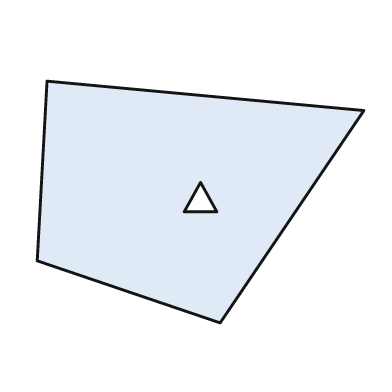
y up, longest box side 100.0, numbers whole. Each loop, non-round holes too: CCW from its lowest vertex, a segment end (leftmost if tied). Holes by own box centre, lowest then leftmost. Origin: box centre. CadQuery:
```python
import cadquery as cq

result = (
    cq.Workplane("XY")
    .moveTo(6.0, -37.0)
    .lineTo(50.0, 28.0)
    .lineTo(-47.0, 37.0)
    .lineTo(-50.0, -18.0)
    .close()
    .moveTo(-5.0, -3.0)
    .lineTo(5.0, -3.0)
    .lineTo(0.0, 6.0)
    .close()
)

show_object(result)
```